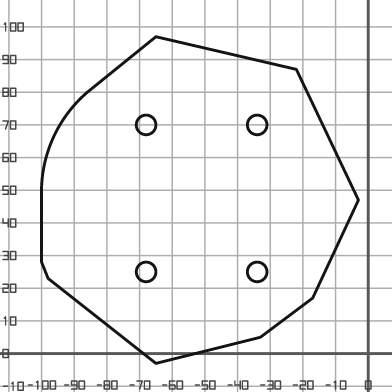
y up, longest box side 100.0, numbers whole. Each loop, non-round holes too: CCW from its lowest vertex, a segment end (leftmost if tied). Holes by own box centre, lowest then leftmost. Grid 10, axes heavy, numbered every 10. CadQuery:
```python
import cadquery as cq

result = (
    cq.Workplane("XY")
    .moveTo(-65.0, -3.0)
    .lineTo(-33.0, 5.0)
    .lineTo(-17.0, 17.0)
    .lineTo(-3.0, 47.0)
    .lineTo(-22.0, 87.0)
    .lineTo(-65.0, 97.0)
    .lineTo(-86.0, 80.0)
    .threePointArc((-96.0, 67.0), (-100.0, 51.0))
    .lineTo(-100.0, 28.0)
    .lineTo(-98.0, 23.0)
    .close()
    .moveTo(-68.0, 25.0)
    .circle(3.0)
    .moveTo(-34.0, 25.0)
    .circle(3.0)
    .moveTo(-68.0, 70.0)
    .circle(3.0)
    .moveTo(-34.0, 70.0)
    .circle(3.0)
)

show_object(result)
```